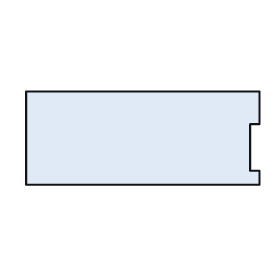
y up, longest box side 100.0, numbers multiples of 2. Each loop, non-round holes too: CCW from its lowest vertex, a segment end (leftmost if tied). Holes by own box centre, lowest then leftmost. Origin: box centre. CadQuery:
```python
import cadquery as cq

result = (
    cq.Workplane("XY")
    .moveTo(-50.0, -20.0)
    .lineTo(50.0, -20.0)
    .lineTo(50.0, -14.0)
    .lineTo(46.0, -14.0)
    .lineTo(46.0, 6.0)
    .lineTo(50.0, 6.0)
    .lineTo(50.0, 20.0)
    .lineTo(-50.0, 20.0)
    .close()
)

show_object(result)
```